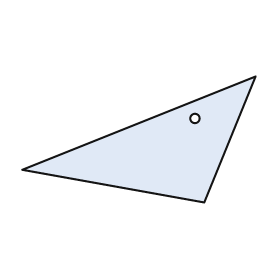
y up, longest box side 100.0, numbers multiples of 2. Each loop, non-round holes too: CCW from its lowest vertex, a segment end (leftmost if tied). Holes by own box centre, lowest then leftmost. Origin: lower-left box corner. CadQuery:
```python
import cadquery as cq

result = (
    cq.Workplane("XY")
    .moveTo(78.0, 0.0)
    .lineTo(100.0, 54.0)
    .lineTo(0.0, 14.0)
    .close()
    .moveTo(74.0, 36.0)
    .circle(2.0)
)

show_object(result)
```